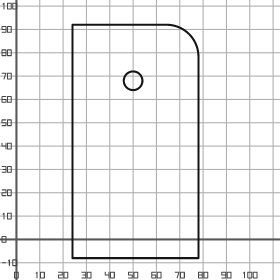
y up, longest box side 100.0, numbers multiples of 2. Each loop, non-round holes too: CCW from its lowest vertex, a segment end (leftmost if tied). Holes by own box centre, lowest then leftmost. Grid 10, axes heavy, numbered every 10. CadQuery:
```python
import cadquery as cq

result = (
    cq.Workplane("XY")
    .moveTo(24.0, -8.0)
    .lineTo(78.0, -8.0)
    .lineTo(78.0, 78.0)
    .threePointArc((74.0, 88.0), (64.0, 92.0))
    .lineTo(24.0, 92.0)
    .close()
    .moveTo(50.0, 68.0)
    .circle(4.0)
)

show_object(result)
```